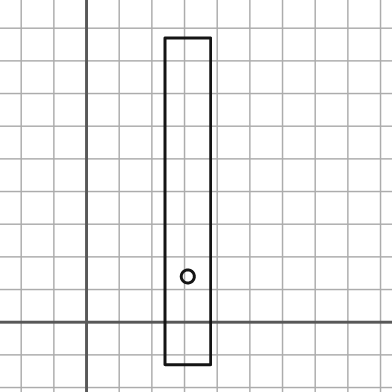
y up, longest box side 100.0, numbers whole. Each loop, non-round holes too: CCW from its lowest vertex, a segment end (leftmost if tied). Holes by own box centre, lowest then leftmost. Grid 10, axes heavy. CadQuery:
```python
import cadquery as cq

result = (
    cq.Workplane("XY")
    .moveTo(24.0, -13.0)
    .lineTo(38.0, -13.0)
    .lineTo(38.0, 87.0)
    .lineTo(24.0, 87.0)
    .close()
    .moveTo(31.0, 14.0)
    .circle(2.0)
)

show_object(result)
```